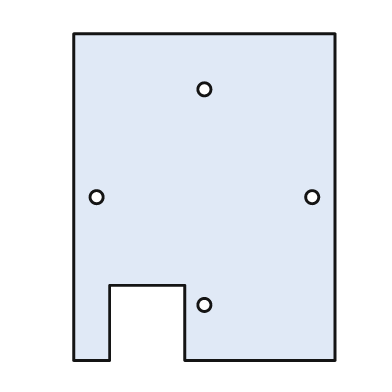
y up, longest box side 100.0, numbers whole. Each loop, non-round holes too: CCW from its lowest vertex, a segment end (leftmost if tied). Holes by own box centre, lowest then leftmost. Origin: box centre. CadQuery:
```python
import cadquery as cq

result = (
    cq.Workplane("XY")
    .moveTo(-40.0, -50.0)
    .lineTo(-29.0, -50.0)
    .lineTo(-29.0, -27.0)
    .lineTo(-6.0, -27.0)
    .lineTo(-6.0, -50.0)
    .lineTo(40.0, -50.0)
    .lineTo(40.0, 50.0)
    .lineTo(-40.0, 50.0)
    .close()
    .moveTo(0.0, -33.0)
    .circle(2.0)
    .moveTo(-33.0, 0.0)
    .circle(2.0)
    .moveTo(33.0, 0.0)
    .circle(2.0)
    .moveTo(0.0, 33.0)
    .circle(2.0)
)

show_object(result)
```